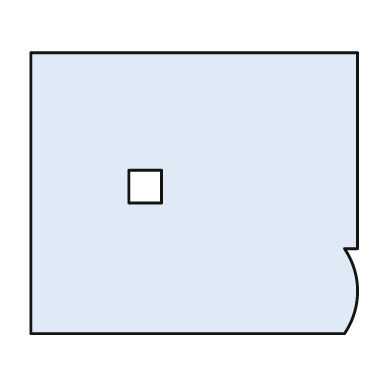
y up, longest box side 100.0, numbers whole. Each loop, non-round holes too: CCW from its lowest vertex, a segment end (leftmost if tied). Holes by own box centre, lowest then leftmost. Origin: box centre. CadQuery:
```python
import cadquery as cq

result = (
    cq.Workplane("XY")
    .moveTo(-50.0, -43.0)
    .lineTo(46.0, -43.0)
    .threePointArc((50.0, -30.0), (46.0, -17.0))
    .lineTo(50.0, -17.0)
    .lineTo(50.0, 43.0)
    .lineTo(-50.0, 43.0)
    .close()
    .moveTo(-20.0, -3.0)
    .lineTo(-10.0, -3.0)
    .lineTo(-10.0, 7.0)
    .lineTo(-20.0, 7.0)
    .close()
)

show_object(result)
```